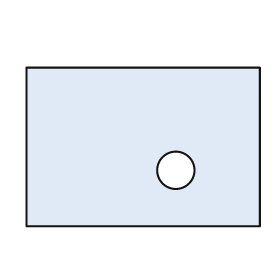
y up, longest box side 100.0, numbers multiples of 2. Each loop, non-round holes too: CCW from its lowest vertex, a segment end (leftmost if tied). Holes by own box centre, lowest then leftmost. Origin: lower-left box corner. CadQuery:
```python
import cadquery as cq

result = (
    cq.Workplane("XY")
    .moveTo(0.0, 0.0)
    .lineTo(100.0, 0.0)
    .lineTo(100.0, 68.0)
    .lineTo(0.0, 68.0)
    .close()
    .moveTo(64.0, 24.0)
    .circle(8.0)
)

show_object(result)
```